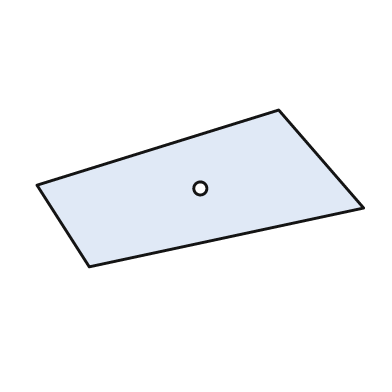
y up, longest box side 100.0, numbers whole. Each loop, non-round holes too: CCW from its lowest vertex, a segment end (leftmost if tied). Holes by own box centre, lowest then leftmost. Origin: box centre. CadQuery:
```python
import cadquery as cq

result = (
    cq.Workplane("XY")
    .moveTo(-34.0, -24.0)
    .lineTo(50.0, -6.0)
    .lineTo(24.0, 24.0)
    .lineTo(-50.0, 1.0)
    .close()
    .moveTo(0.0, 0.0)
    .circle(2.0)
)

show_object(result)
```